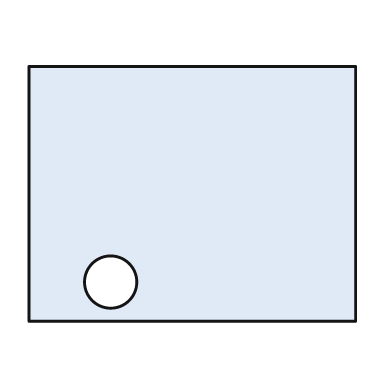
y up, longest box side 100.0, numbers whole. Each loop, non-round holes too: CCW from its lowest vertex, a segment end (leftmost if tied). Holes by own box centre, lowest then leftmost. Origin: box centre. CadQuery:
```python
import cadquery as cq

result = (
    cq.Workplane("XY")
    .moveTo(-50.0, -39.0)
    .lineTo(50.0, -39.0)
    .lineTo(50.0, 39.0)
    .lineTo(-50.0, 39.0)
    .close()
    .moveTo(-25.0, -27.0)
    .circle(8.0)
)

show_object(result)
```